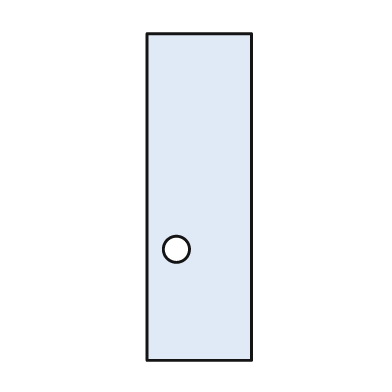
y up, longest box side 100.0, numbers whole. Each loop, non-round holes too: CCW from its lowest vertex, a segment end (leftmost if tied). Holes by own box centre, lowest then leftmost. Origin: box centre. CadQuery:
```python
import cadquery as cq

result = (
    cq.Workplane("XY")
    .moveTo(-16.0, -50.0)
    .lineTo(16.0, -50.0)
    .lineTo(16.0, 50.0)
    .lineTo(-16.0, 50.0)
    .close()
    .moveTo(-7.0, -16.0)
    .circle(4.0)
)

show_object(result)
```